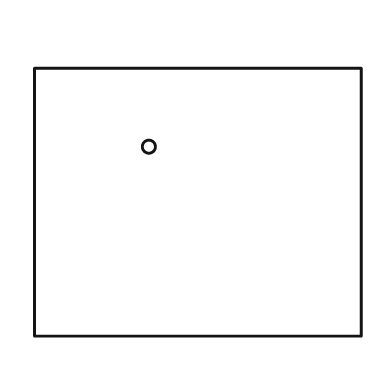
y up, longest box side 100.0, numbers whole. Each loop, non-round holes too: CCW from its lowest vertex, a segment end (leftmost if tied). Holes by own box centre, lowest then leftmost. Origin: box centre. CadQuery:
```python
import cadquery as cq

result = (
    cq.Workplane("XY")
    .moveTo(-50.0, -41.0)
    .lineTo(50.0, -41.0)
    .lineTo(50.0, 41.0)
    .lineTo(-50.0, 41.0)
    .close()
    .moveTo(-15.0, 17.0)
    .circle(2.0)
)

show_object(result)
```